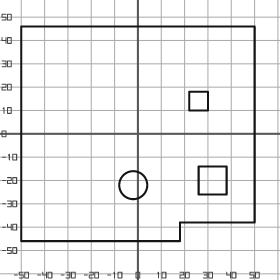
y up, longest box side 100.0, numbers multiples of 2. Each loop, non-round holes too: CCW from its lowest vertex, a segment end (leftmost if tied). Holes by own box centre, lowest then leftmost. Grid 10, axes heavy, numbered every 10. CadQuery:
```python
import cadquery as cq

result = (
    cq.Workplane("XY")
    .moveTo(-50.0, -46.0)
    .lineTo(18.0, -46.0)
    .lineTo(18.0, -38.0)
    .lineTo(50.0, -38.0)
    .lineTo(50.0, 46.0)
    .lineTo(-50.0, 46.0)
    .close()
    .moveTo(-2.0, -22.0)
    .circle(6.0)
    .moveTo(26.0, -26.0)
    .lineTo(38.0, -26.0)
    .lineTo(38.0, -14.0)
    .lineTo(26.0, -14.0)
    .close()
    .moveTo(22.0, 10.0)
    .lineTo(30.0, 10.0)
    .lineTo(30.0, 18.0)
    .lineTo(22.0, 18.0)
    .close()
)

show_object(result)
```